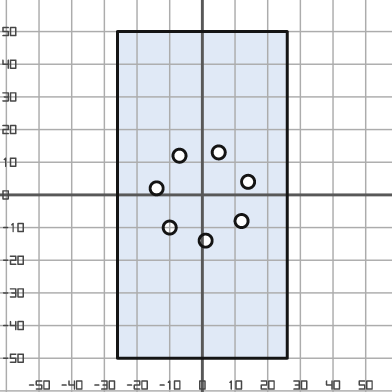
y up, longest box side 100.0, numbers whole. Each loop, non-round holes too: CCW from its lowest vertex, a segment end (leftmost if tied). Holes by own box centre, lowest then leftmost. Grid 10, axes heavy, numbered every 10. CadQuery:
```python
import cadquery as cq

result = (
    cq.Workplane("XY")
    .moveTo(-26.0, -50.0)
    .lineTo(26.0, -50.0)
    .lineTo(26.0, 50.0)
    .lineTo(-26.0, 50.0)
    .close()
    .moveTo(1.0, -14.0)
    .circle(2.0)
    .moveTo(-10.0, -10.0)
    .circle(2.0)
    .moveTo(12.0, -8.0)
    .circle(2.0)
    .moveTo(-14.0, 2.0)
    .circle(2.0)
    .moveTo(14.0, 4.0)
    .circle(2.0)
    .moveTo(-7.0, 12.0)
    .circle(2.0)
    .moveTo(5.0, 13.0)
    .circle(2.0)
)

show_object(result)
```